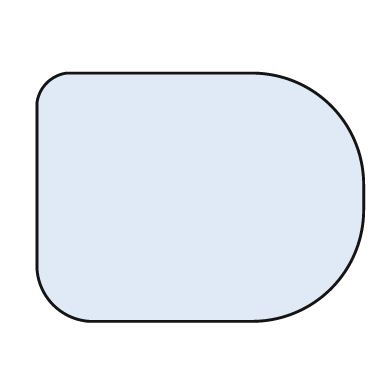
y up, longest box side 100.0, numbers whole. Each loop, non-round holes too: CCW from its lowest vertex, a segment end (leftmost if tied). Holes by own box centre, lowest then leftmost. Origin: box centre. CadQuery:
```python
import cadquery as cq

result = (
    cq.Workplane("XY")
    .moveTo(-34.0, -38.0)
    .lineTo(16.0, -38.0)
    .threePointArc((40.0, -28.0), (50.0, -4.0))
    .lineTo(50.0, 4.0)
    .threePointArc((40.0, 28.0), (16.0, 38.0))
    .lineTo(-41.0, 38.0)
    .threePointArc((-47.0, 35.0), (-50.0, 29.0))
    .lineTo(-50.0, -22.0)
    .threePointArc((-45.0, -33.0), (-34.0, -38.0))
    .close()
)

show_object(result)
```